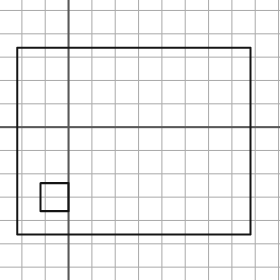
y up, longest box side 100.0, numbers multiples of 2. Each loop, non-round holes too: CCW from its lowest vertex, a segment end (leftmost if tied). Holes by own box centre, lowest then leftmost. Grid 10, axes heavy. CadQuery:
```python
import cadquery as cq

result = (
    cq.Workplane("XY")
    .moveTo(-22.0, -46.0)
    .lineTo(78.0, -46.0)
    .lineTo(78.0, 34.0)
    .lineTo(-22.0, 34.0)
    .close()
    .moveTo(-12.0, -36.0)
    .lineTo(0.0, -36.0)
    .lineTo(0.0, -24.0)
    .lineTo(-12.0, -24.0)
    .close()
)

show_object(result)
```